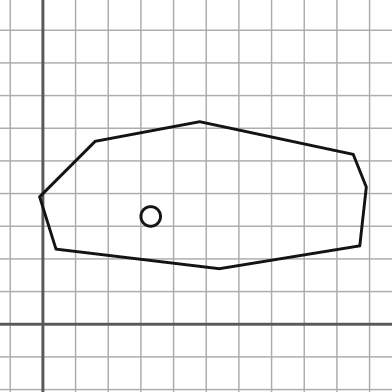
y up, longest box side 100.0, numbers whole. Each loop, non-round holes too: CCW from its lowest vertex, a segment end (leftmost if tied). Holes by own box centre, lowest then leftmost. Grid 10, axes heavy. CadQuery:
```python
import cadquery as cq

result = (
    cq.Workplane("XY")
    .moveTo(54.0, 17.0)
    .lineTo(97.0, 24.0)
    .lineTo(99.0, 42.0)
    .lineTo(95.0, 52.0)
    .lineTo(48.0, 62.0)
    .lineTo(16.0, 56.0)
    .lineTo(-1.0, 39.0)
    .lineTo(4.0, 23.0)
    .close()
    .moveTo(33.0, 33.0)
    .circle(3.0)
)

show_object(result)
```